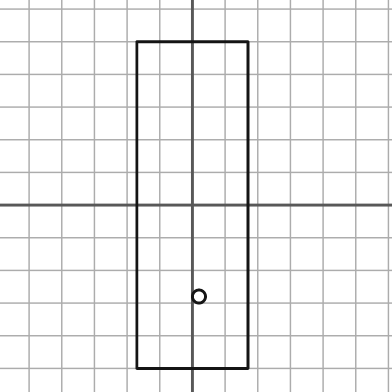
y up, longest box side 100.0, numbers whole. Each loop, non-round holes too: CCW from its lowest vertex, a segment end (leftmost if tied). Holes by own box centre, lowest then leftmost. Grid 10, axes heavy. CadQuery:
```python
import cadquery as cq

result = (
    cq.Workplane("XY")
    .moveTo(-17.0, -50.0)
    .lineTo(17.0, -50.0)
    .lineTo(17.0, 50.0)
    .lineTo(-17.0, 50.0)
    .close()
    .moveTo(2.0, -28.0)
    .circle(2.0)
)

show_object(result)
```